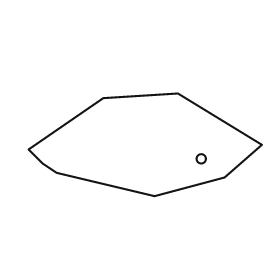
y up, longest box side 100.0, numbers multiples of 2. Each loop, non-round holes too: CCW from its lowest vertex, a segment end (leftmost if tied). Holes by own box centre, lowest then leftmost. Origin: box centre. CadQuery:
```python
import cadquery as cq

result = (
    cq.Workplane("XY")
    .moveTo(4.0, -22.0)
    .lineTo(34.0, -14.0)
    .lineTo(50.0, 0.0)
    .lineTo(14.0, 22.0)
    .lineTo(-18.0, 20.0)
    .lineTo(-50.0, -2.0)
    .lineTo(-44.0, -8.0)
    .lineTo(-38.0, -12.0)
    .close()
    .moveTo(24.0, -6.0)
    .circle(2.0)
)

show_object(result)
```